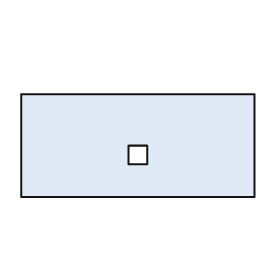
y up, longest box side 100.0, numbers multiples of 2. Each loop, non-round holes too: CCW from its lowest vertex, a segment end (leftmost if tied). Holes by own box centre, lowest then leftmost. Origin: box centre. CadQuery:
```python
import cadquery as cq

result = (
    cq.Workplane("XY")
    .moveTo(-50.0, -22.0)
    .lineTo(50.0, -22.0)
    .lineTo(50.0, 22.0)
    .lineTo(-50.0, 22.0)
    .close()
    .moveTo(-4.0, -8.0)
    .lineTo(4.0, -8.0)
    .lineTo(4.0, 0.0)
    .lineTo(-4.0, 0.0)
    .close()
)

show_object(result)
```